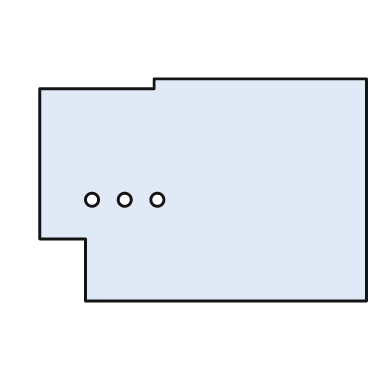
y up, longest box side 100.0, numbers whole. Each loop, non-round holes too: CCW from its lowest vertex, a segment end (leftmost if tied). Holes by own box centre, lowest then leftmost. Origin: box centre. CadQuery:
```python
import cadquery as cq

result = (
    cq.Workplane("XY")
    .moveTo(-36.0, -34.0)
    .lineTo(50.0, -34.0)
    .lineTo(50.0, 34.0)
    .lineTo(-15.0, 34.0)
    .lineTo(-15.0, 31.0)
    .lineTo(-50.0, 31.0)
    .lineTo(-50.0, -15.0)
    .lineTo(-36.0, -15.0)
    .close()
    .moveTo(-34.0, -3.0)
    .circle(2.0)
    .moveTo(-24.0, -3.0)
    .circle(2.0)
    .moveTo(-14.0, -3.0)
    .circle(2.0)
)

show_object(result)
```